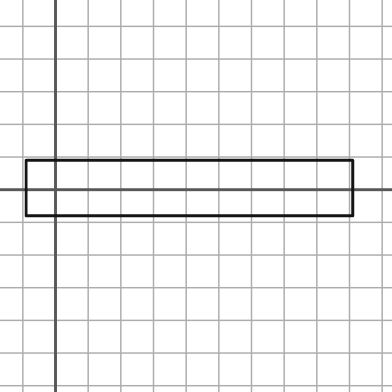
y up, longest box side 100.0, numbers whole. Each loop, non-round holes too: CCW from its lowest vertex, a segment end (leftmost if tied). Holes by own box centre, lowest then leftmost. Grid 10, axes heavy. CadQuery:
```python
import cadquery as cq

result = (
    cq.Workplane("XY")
    .moveTo(-9.0, -8.0)
    .lineTo(91.0, -8.0)
    .lineTo(91.0, 9.0)
    .lineTo(-9.0, 9.0)
    .close()
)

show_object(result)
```